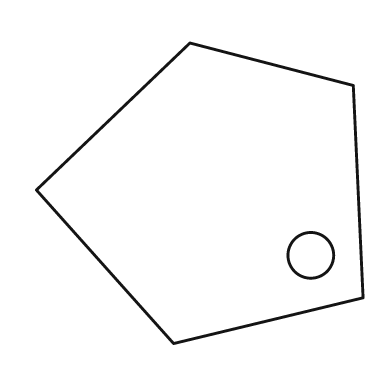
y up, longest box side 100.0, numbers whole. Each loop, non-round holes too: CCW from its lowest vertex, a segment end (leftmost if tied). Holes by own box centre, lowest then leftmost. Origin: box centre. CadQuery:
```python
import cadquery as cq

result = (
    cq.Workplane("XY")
    .moveTo(-8.0, -46.0)
    .lineTo(50.0, -32.0)
    .lineTo(47.0, 33.0)
    .lineTo(-3.0, 46.0)
    .lineTo(-50.0, 1.0)
    .close()
    .moveTo(34.0, -19.0)
    .circle(7.0)
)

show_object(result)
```